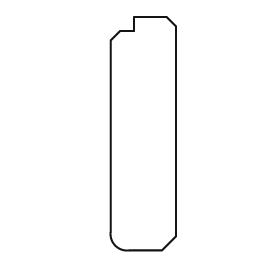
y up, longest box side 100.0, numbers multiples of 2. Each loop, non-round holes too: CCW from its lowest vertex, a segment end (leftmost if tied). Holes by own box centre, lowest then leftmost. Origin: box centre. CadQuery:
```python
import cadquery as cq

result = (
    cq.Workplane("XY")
    .moveTo(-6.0, -50.0)
    .lineTo(8.0, -50.0)
    .lineTo(14.0, -44.0)
    .lineTo(14.0, 46.0)
    .lineTo(10.0, 50.0)
    .lineTo(-4.0, 50.0)
    .lineTo(-4.0, 44.0)
    .lineTo(-10.0, 44.0)
    .lineTo(-14.0, 40.0)
    .lineTo(-14.0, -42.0)
    .threePointArc((-12.0, -48.0), (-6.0, -50.0))
    .close()
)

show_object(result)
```